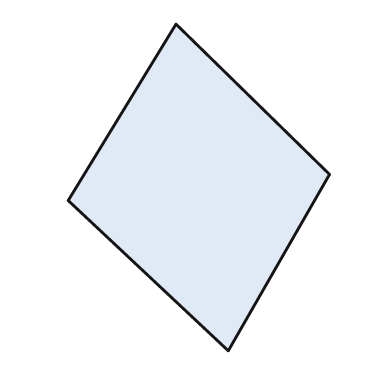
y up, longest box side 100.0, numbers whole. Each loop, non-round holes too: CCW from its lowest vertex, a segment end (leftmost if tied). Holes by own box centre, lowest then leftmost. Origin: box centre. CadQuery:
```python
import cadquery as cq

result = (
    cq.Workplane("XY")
    .moveTo(9.0, -50.0)
    .lineTo(40.0, 4.0)
    .lineTo(-7.0, 50.0)
    .lineTo(-40.0, -4.0)
    .close()
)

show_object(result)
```